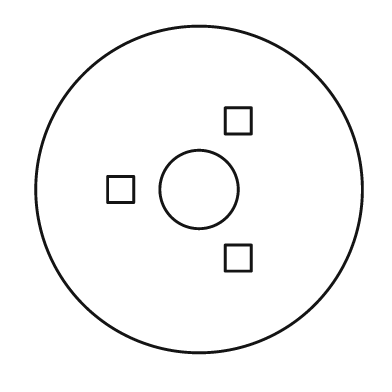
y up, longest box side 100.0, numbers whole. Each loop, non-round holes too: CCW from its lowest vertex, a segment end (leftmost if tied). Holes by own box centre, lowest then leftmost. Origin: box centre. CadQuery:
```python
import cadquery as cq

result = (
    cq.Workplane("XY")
    .moveTo(0.0, 0.0)
    .circle(50.0)
    .moveTo(8.0, -25.0)
    .lineTo(16.0, -25.0)
    .lineTo(16.0, -17.0)
    .lineTo(8.0, -17.0)
    .close()
    .moveTo(-28.0, -4.0)
    .lineTo(-20.0, -4.0)
    .lineTo(-20.0, 4.0)
    .lineTo(-28.0, 4.0)
    .close()
    .moveTo(0.0, 0.0)
    .circle(12.0)
    .moveTo(8.0, 17.0)
    .lineTo(16.0, 17.0)
    .lineTo(16.0, 25.0)
    .lineTo(8.0, 25.0)
    .close()
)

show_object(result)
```